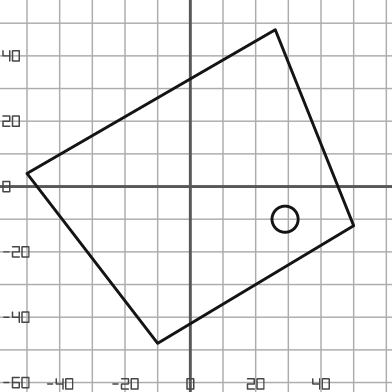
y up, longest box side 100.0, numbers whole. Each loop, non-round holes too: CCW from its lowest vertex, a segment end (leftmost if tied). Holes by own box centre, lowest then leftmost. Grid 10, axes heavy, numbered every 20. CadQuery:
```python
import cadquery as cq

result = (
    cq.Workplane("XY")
    .moveTo(-10.0, -48.0)
    .lineTo(50.0, -12.0)
    .lineTo(26.0, 48.0)
    .lineTo(-50.0, 4.0)
    .close()
    .moveTo(29.0, -10.0)
    .circle(4.0)
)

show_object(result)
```